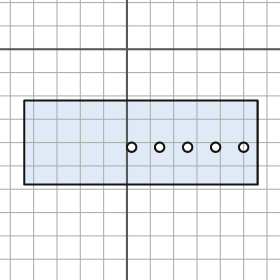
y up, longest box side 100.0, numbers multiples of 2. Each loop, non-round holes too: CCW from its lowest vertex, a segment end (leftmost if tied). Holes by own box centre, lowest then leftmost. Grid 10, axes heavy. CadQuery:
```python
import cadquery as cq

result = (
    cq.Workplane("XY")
    .moveTo(-44.0, -58.0)
    .lineTo(56.0, -58.0)
    .lineTo(56.0, -22.0)
    .lineTo(-44.0, -22.0)
    .close()
    .moveTo(2.0, -42.0)
    .circle(2.0)
    .moveTo(14.0, -42.0)
    .circle(2.0)
    .moveTo(26.0, -42.0)
    .circle(2.0)
    .moveTo(38.0, -42.0)
    .circle(2.0)
    .moveTo(50.0, -42.0)
    .circle(2.0)
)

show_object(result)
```